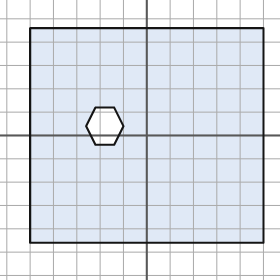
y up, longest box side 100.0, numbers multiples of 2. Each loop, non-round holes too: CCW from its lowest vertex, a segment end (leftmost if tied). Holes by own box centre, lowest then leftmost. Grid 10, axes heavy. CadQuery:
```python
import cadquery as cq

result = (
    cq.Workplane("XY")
    .moveTo(-50.0, -46.0)
    .lineTo(50.0, -46.0)
    .lineTo(50.0, 46.0)
    .lineTo(-50.0, 46.0)
    .close()
    .moveTo(-22.0, -4.0)
    .lineTo(-14.0, -4.0)
    .lineTo(-10.0, 4.0)
    .lineTo(-14.0, 12.0)
    .lineTo(-22.0, 12.0)
    .lineTo(-26.0, 4.0)
    .close()
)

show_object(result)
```